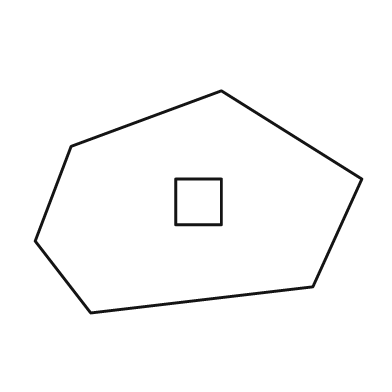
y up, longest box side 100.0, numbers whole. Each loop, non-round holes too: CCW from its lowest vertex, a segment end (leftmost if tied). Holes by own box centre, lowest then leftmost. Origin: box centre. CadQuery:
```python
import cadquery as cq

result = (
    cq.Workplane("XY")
    .moveTo(-33.0, -34.0)
    .lineTo(35.0, -26.0)
    .lineTo(50.0, 7.0)
    .lineTo(7.0, 34.0)
    .lineTo(-39.0, 17.0)
    .lineTo(-50.0, -12.0)
    .close()
    .moveTo(-7.0, -7.0)
    .lineTo(7.0, -7.0)
    .lineTo(7.0, 7.0)
    .lineTo(-7.0, 7.0)
    .close()
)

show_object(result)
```